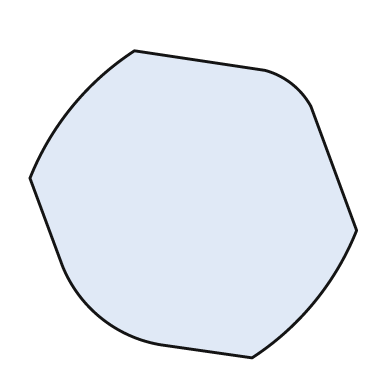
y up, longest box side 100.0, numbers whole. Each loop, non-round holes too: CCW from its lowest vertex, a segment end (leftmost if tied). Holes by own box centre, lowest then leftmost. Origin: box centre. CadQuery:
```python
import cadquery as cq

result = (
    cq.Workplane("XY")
    .moveTo(18.0, -47.0)
    .threePointArc((37.0, -30.0), (50.0, -8.0))
    .lineTo(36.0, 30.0)
    .threePointArc((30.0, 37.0), (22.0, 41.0))
    .lineTo(-18.0, 47.0)
    .threePointArc((-37.0, 30.0), (-50.0, 8.0))
    .lineTo(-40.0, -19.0)
    .threePointArc((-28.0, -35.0), (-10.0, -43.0))
    .close()
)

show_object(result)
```